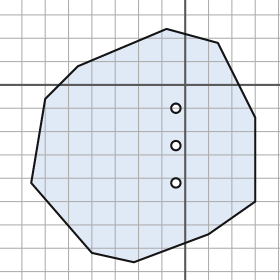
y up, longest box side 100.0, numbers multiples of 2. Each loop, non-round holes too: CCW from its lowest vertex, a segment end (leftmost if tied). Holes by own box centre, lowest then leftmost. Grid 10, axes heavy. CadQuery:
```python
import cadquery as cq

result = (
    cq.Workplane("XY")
    .moveTo(-22.0, -76.0)
    .lineTo(10.0, -64.0)
    .lineTo(30.0, -50.0)
    .lineTo(30.0, -14.0)
    .lineTo(14.0, 18.0)
    .lineTo(-8.0, 24.0)
    .lineTo(-46.0, 8.0)
    .lineTo(-60.0, -6.0)
    .lineTo(-66.0, -42.0)
    .lineTo(-40.0, -72.0)
    .close()
    .moveTo(-4.0, -42.0)
    .circle(2.0)
    .moveTo(-4.0, -26.0)
    .circle(2.0)
    .moveTo(-4.0, -10.0)
    .circle(2.0)
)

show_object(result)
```